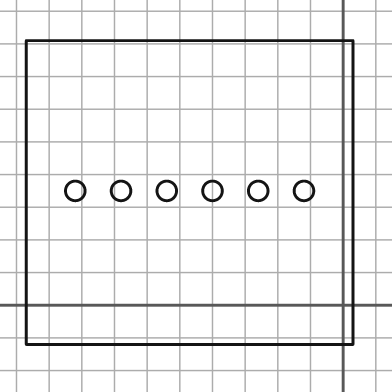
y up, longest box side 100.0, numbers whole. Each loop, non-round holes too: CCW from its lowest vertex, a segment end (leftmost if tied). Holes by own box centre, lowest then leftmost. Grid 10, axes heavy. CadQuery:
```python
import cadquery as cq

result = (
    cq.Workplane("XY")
    .moveTo(-97.0, -12.0)
    .lineTo(3.0, -12.0)
    .lineTo(3.0, 81.0)
    .lineTo(-97.0, 81.0)
    .close()
    .moveTo(-82.0, 35.0)
    .circle(3.0)
    .moveTo(-68.0, 35.0)
    .circle(3.0)
    .moveTo(-54.0, 35.0)
    .circle(3.0)
    .moveTo(-40.0, 35.0)
    .circle(3.0)
    .moveTo(-26.0, 35.0)
    .circle(3.0)
    .moveTo(-12.0, 35.0)
    .circle(3.0)
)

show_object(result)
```